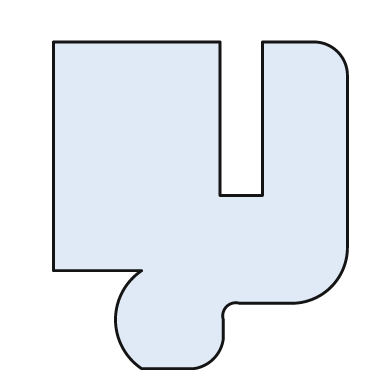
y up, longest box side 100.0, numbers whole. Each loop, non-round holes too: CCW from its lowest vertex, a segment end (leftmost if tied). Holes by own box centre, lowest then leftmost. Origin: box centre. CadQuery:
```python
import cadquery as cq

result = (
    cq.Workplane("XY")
    .moveTo(-18.0, -50.0)
    .lineTo(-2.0, -50.0)
    .threePointArc((4.0, -47.0), (7.0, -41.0))
    .lineTo(7.0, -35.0)
    .threePointArc((8.0, -31.0), (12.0, -30.0))
    .lineTo(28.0, -30.0)
    .threePointArc((40.0, -25.0), (45.0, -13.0))
    .lineTo(45.0, 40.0)
    .threePointArc((42.0, 47.0), (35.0, 50.0))
    .lineTo(19.0, 50.0)
    .lineTo(19.0, 3.0)
    .lineTo(6.0, 3.0)
    .lineTo(6.0, 50.0)
    .lineTo(-45.0, 50.0)
    .lineTo(-45.0, -20.0)
    .lineTo(-18.0, -20.0)
    .threePointArc((-26.0, -35.0), (-18.0, -50.0))
    .close()
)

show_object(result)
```